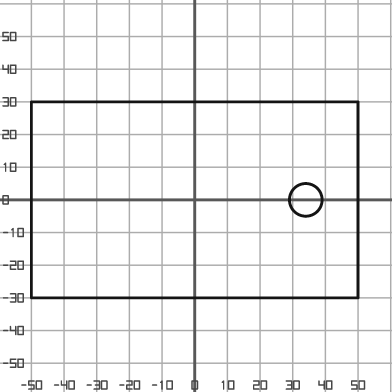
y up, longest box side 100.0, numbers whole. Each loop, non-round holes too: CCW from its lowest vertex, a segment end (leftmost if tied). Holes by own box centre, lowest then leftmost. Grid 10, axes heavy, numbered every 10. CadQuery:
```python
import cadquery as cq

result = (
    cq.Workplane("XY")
    .moveTo(-50.0, -30.0)
    .lineTo(50.0, -30.0)
    .lineTo(50.0, 30.0)
    .lineTo(-50.0, 30.0)
    .close()
    .moveTo(34.0, 0.0)
    .circle(5.0)
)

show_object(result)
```